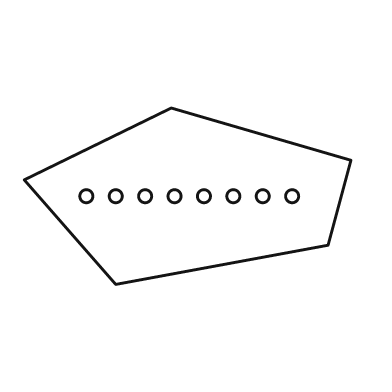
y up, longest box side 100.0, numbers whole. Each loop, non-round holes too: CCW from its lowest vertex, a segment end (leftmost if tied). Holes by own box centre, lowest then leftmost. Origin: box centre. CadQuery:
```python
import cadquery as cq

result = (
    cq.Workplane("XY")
    .moveTo(-22.0, -27.0)
    .lineTo(43.0, -15.0)
    .lineTo(50.0, 11.0)
    .lineTo(-5.0, 27.0)
    .lineTo(-50.0, 5.0)
    .close()
    .moveTo(-31.0, 0.0)
    .circle(2.0)
    .moveTo(-22.0, 0.0)
    .circle(2.0)
    .moveTo(-13.0, 0.0)
    .circle(2.0)
    .moveTo(-4.0, 0.0)
    .circle(2.0)
    .moveTo(5.0, 0.0)
    .circle(2.0)
    .moveTo(14.0, 0.0)
    .circle(2.0)
    .moveTo(23.0, 0.0)
    .circle(2.0)
    .moveTo(32.0, 0.0)
    .circle(2.0)
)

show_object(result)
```